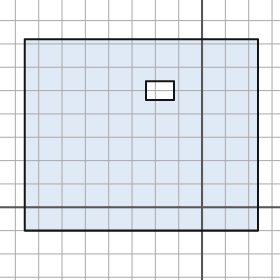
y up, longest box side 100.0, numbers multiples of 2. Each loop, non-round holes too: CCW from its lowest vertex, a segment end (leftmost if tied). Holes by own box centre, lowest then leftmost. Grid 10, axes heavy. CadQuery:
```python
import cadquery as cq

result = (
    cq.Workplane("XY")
    .moveTo(-76.0, -10.0)
    .lineTo(24.0, -10.0)
    .lineTo(24.0, 72.0)
    .lineTo(-76.0, 72.0)
    .close()
    .moveTo(-24.0, 46.0)
    .lineTo(-12.0, 46.0)
    .lineTo(-12.0, 54.0)
    .lineTo(-24.0, 54.0)
    .close()
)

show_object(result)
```